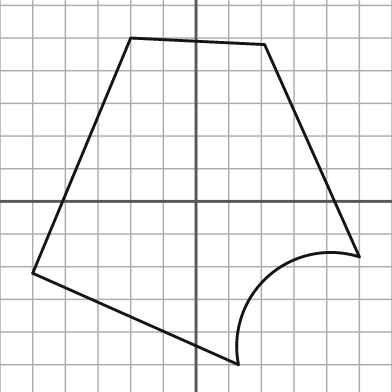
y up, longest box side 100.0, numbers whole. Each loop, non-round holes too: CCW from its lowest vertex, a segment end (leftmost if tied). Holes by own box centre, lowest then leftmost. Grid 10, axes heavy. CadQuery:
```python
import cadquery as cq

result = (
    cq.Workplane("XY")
    .moveTo(13.0, -50.0)
    .threePointArc((22.0, -23.0), (50.0, -17.0))
    .lineTo(21.0, 48.0)
    .lineTo(-20.0, 50.0)
    .lineTo(-50.0, -22.0)
    .close()
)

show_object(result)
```